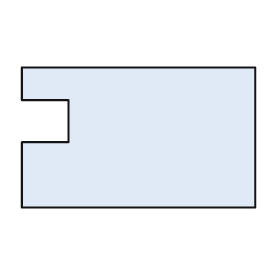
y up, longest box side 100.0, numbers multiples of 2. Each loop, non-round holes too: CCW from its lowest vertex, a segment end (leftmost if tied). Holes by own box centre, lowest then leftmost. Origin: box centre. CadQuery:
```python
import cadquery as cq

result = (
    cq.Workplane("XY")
    .moveTo(-50.0, -30.0)
    .lineTo(50.0, -30.0)
    .lineTo(50.0, 30.0)
    .lineTo(-50.0, 30.0)
    .lineTo(-50.0, 16.0)
    .lineTo(-30.0, 16.0)
    .lineTo(-30.0, -2.0)
    .lineTo(-50.0, -2.0)
    .close()
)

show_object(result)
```